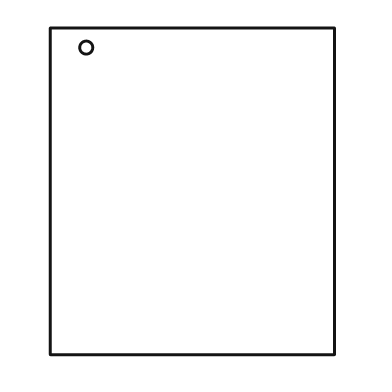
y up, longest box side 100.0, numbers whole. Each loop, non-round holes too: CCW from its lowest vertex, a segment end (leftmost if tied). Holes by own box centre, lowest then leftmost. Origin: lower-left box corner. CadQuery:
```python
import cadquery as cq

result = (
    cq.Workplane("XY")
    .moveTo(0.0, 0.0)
    .lineTo(87.0, 0.0)
    .lineTo(87.0, 100.0)
    .lineTo(0.0, 100.0)
    .close()
    .moveTo(11.0, 94.0)
    .circle(2.0)
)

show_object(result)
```